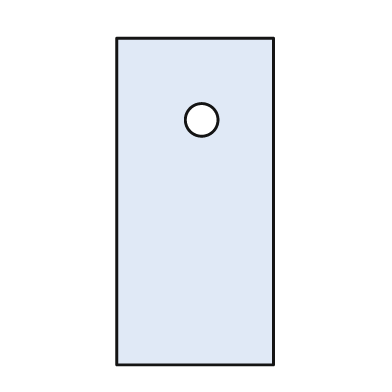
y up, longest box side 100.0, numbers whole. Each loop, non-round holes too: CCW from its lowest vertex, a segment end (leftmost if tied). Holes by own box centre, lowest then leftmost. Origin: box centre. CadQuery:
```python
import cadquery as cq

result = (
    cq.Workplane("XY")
    .moveTo(-24.0, -50.0)
    .lineTo(24.0, -50.0)
    .lineTo(24.0, 50.0)
    .lineTo(-24.0, 50.0)
    .close()
    .moveTo(2.0, 25.0)
    .circle(5.0)
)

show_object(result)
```